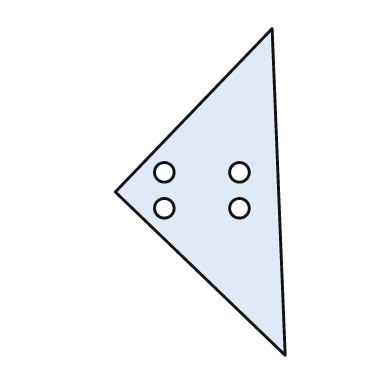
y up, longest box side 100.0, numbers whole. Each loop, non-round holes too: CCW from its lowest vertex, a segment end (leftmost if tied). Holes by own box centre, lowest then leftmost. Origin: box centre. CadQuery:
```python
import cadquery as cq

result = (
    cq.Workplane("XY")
    .moveTo(26.0, -50.0)
    .lineTo(22.0, 50.0)
    .lineTo(-26.0, 0.0)
    .close()
    .moveTo(-11.0, -5.0)
    .circle(3.0)
    .moveTo(12.0, -5.0)
    .circle(3.0)
    .moveTo(-11.0, 6.0)
    .circle(3.0)
    .moveTo(12.0, 6.0)
    .circle(3.0)
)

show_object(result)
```